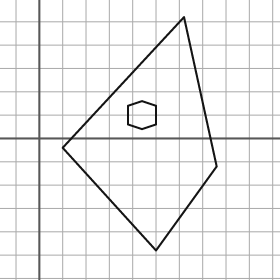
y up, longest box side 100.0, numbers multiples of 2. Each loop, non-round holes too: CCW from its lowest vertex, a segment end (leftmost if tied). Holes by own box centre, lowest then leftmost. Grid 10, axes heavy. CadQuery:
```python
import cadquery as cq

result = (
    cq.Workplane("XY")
    .moveTo(50.0, -48.0)
    .lineTo(76.0, -12.0)
    .lineTo(62.0, 52.0)
    .lineTo(10.0, -4.0)
    .close()
    .moveTo(44.0, 4.0)
    .lineTo(50.0, 6.0)
    .lineTo(50.0, 14.0)
    .lineTo(44.0, 16.0)
    .lineTo(38.0, 14.0)
    .lineTo(38.0, 6.0)
    .close()
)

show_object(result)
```